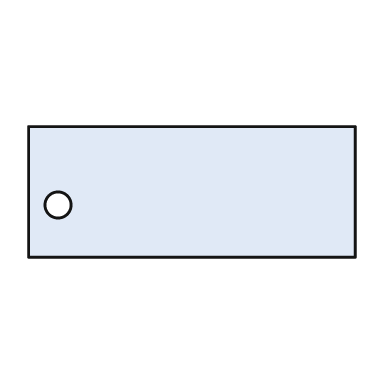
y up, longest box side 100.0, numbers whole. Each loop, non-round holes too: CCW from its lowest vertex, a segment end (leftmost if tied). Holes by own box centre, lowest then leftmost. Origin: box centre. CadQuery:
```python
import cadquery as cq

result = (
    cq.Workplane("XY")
    .moveTo(-50.0, -20.0)
    .lineTo(50.0, -20.0)
    .lineTo(50.0, 20.0)
    .lineTo(-50.0, 20.0)
    .close()
    .moveTo(-41.0, -4.0)
    .circle(4.0)
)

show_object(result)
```